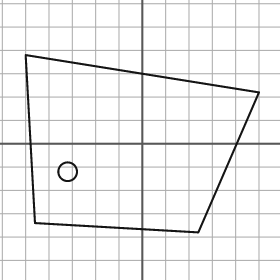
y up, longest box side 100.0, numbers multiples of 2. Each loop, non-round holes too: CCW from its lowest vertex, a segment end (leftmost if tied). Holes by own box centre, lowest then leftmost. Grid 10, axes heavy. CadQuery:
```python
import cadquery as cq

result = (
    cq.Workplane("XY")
    .moveTo(24.0, -38.0)
    .lineTo(50.0, 22.0)
    .lineTo(-50.0, 38.0)
    .lineTo(-46.0, -34.0)
    .close()
    .moveTo(-32.0, -12.0)
    .circle(4.0)
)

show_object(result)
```